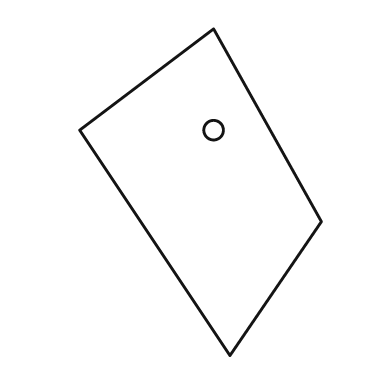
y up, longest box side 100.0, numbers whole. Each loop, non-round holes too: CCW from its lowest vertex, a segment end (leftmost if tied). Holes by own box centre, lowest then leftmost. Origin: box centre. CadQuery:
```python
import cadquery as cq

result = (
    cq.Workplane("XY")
    .moveTo(9.0, -50.0)
    .lineTo(37.0, -9.0)
    .lineTo(4.0, 50.0)
    .lineTo(-37.0, 19.0)
    .close()
    .moveTo(4.0, 19.0)
    .circle(3.0)
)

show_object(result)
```